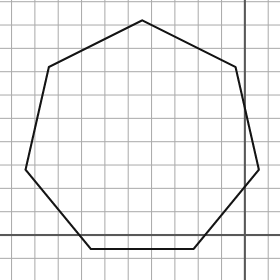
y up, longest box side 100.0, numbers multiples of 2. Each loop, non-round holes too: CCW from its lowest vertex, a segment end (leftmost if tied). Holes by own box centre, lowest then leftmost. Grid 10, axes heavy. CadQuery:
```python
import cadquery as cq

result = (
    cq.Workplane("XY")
    .moveTo(-66.0, -6.0)
    .lineTo(-22.0, -6.0)
    .lineTo(6.0, 28.0)
    .lineTo(-4.0, 72.0)
    .lineTo(-44.0, 92.0)
    .lineTo(-84.0, 72.0)
    .lineTo(-94.0, 28.0)
    .close()
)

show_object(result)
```